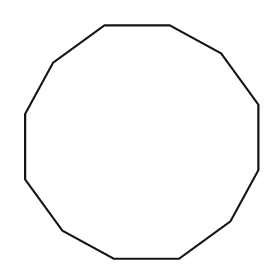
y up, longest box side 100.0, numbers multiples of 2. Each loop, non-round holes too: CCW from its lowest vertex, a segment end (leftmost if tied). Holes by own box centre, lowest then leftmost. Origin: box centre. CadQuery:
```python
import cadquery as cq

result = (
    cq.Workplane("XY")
    .moveTo(-12.0, -50.0)
    .lineTo(16.0, -50.0)
    .lineTo(38.0, -34.0)
    .lineTo(50.0, -12.0)
    .lineTo(50.0, 16.0)
    .lineTo(34.0, 38.0)
    .lineTo(12.0, 50.0)
    .lineTo(-16.0, 50.0)
    .lineTo(-38.0, 34.0)
    .lineTo(-50.0, 12.0)
    .lineTo(-50.0, -16.0)
    .lineTo(-34.0, -38.0)
    .close()
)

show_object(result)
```